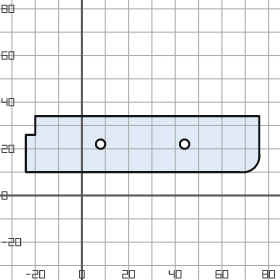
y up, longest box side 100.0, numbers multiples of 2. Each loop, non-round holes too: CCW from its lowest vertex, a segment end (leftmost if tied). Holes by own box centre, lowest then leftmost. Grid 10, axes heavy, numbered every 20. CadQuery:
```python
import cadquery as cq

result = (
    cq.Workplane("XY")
    .moveTo(-24.0, 10.0)
    .lineTo(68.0, 10.0)
    .threePointArc((74.0, 12.0), (76.0, 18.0))
    .lineTo(76.0, 34.0)
    .lineTo(-20.0, 34.0)
    .lineTo(-20.0, 26.0)
    .lineTo(-24.0, 26.0)
    .close()
    .moveTo(8.0, 22.0)
    .circle(2.0)
    .moveTo(44.0, 22.0)
    .circle(2.0)
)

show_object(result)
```